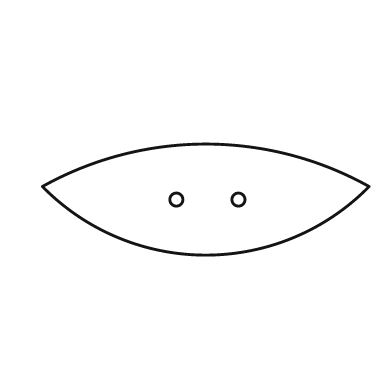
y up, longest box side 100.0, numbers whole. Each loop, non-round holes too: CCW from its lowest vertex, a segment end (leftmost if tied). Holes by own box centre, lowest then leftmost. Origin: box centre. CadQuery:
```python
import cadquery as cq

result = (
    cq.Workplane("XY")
    .moveTo(-50.0, 4.0)
    .threePointArc((0.0, -17.0), (50.0, 4.0))
    .threePointArc((0.0, 17.0), (-50.0, 4.0))
    .close()
    .moveTo(-9.0, 0.0)
    .circle(2.0)
    .moveTo(10.0, 0.0)
    .circle(2.0)
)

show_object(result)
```